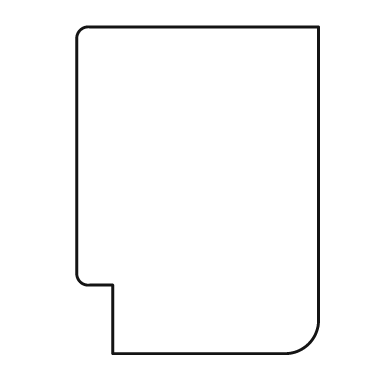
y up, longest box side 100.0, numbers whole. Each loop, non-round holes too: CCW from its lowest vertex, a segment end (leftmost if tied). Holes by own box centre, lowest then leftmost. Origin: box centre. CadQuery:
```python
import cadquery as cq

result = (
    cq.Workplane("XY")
    .moveTo(-26.0, -50.0)
    .lineTo(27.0, -50.0)
    .threePointArc((34.0, -47.0), (37.0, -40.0))
    .lineTo(37.0, 50.0)
    .lineTo(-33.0, 50.0)
    .threePointArc((-36.0, 49.0), (-37.0, 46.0))
    .lineTo(-37.0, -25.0)
    .threePointArc((-36.0, -28.0), (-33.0, -29.0))
    .lineTo(-26.0, -29.0)
    .close()
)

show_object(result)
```